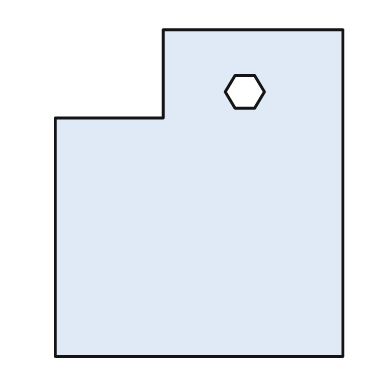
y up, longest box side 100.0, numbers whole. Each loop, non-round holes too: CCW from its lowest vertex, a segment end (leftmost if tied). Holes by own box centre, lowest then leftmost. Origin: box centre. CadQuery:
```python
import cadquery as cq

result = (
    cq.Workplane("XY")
    .moveTo(-44.0, -50.0)
    .lineTo(44.0, -50.0)
    .lineTo(44.0, 50.0)
    .lineTo(-11.0, 50.0)
    .lineTo(-11.0, 23.0)
    .lineTo(-44.0, 23.0)
    .close()
    .moveTo(11.0, 26.0)
    .lineTo(17.0, 26.0)
    .lineTo(20.0, 31.0)
    .lineTo(17.0, 36.0)
    .lineTo(11.0, 36.0)
    .lineTo(8.0, 31.0)
    .close()
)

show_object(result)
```